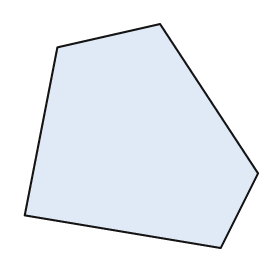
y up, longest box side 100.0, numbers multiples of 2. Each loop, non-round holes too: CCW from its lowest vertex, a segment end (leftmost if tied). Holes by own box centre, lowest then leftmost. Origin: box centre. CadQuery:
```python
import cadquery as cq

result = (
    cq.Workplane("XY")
    .moveTo(34.0, -48.0)
    .lineTo(50.0, -16.0)
    .lineTo(8.0, 48.0)
    .lineTo(-36.0, 38.0)
    .lineTo(-50.0, -34.0)
    .close()
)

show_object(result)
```